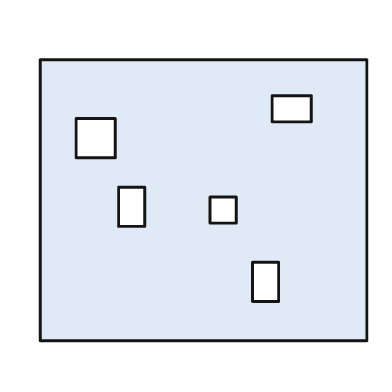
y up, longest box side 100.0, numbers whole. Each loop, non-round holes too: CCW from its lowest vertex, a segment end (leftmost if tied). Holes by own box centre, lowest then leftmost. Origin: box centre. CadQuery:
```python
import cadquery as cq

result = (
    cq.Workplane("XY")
    .moveTo(-50.0, -43.0)
    .lineTo(50.0, -43.0)
    .lineTo(50.0, 43.0)
    .lineTo(-50.0, 43.0)
    .close()
    .moveTo(15.0, -31.0)
    .lineTo(23.0, -31.0)
    .lineTo(23.0, -19.0)
    .lineTo(15.0, -19.0)
    .close()
    .moveTo(2.0, -7.0)
    .lineTo(10.0, -7.0)
    .lineTo(10.0, 1.0)
    .lineTo(2.0, 1.0)
    .close()
    .moveTo(-26.0, -8.0)
    .lineTo(-18.0, -8.0)
    .lineTo(-18.0, 4.0)
    .lineTo(-26.0, 4.0)
    .close()
    .moveTo(-39.0, 13.0)
    .lineTo(-27.0, 13.0)
    .lineTo(-27.0, 25.0)
    .lineTo(-39.0, 25.0)
    .close()
    .moveTo(21.0, 24.0)
    .lineTo(33.0, 24.0)
    .lineTo(33.0, 32.0)
    .lineTo(21.0, 32.0)
    .close()
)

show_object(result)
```